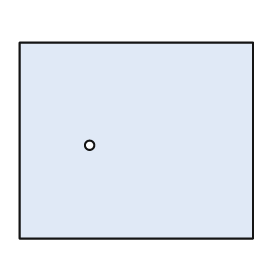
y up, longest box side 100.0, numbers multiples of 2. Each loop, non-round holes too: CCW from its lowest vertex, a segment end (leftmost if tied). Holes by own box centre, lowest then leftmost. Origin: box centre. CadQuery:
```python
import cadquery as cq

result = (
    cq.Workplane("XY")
    .moveTo(-50.0, -42.0)
    .lineTo(50.0, -42.0)
    .lineTo(50.0, 42.0)
    .lineTo(-50.0, 42.0)
    .close()
    .moveTo(-20.0, -2.0)
    .circle(2.0)
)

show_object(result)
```